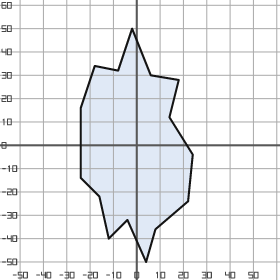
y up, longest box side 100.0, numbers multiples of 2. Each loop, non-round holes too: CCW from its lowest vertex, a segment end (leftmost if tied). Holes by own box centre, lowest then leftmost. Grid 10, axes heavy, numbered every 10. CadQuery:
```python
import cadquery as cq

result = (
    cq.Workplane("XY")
    .moveTo(4.0, -50.0)
    .lineTo(8.0, -36.0)
    .lineTo(22.0, -24.0)
    .lineTo(24.0, -4.0)
    .lineTo(14.0, 12.0)
    .lineTo(18.0, 28.0)
    .lineTo(6.0, 30.0)
    .lineTo(-2.0, 50.0)
    .lineTo(-8.0, 32.0)
    .lineTo(-18.0, 34.0)
    .lineTo(-24.0, 16.0)
    .lineTo(-24.0, -14.0)
    .lineTo(-16.0, -22.0)
    .lineTo(-12.0, -40.0)
    .lineTo(-4.0, -32.0)
    .close()
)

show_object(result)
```